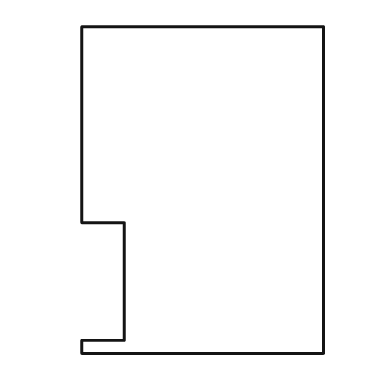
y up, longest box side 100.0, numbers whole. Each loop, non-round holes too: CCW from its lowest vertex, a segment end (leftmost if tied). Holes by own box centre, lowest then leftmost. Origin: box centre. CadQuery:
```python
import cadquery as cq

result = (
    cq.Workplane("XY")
    .moveTo(-37.0, -50.0)
    .lineTo(37.0, -50.0)
    .lineTo(37.0, 50.0)
    .lineTo(-37.0, 50.0)
    .lineTo(-37.0, -10.0)
    .lineTo(-24.0, -10.0)
    .lineTo(-24.0, -46.0)
    .lineTo(-37.0, -46.0)
    .close()
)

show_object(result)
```